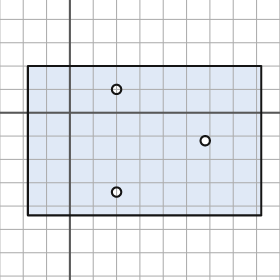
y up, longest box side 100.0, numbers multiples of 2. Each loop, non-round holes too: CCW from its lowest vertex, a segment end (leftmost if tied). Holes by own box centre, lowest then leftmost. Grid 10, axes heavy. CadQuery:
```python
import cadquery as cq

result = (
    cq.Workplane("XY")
    .moveTo(-18.0, -44.0)
    .lineTo(82.0, -44.0)
    .lineTo(82.0, 20.0)
    .lineTo(-18.0, 20.0)
    .close()
    .moveTo(20.0, -34.0)
    .circle(2.0)
    .moveTo(58.0, -12.0)
    .circle(2.0)
    .moveTo(20.0, 10.0)
    .circle(2.0)
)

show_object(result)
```